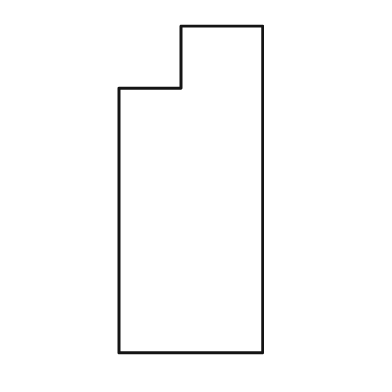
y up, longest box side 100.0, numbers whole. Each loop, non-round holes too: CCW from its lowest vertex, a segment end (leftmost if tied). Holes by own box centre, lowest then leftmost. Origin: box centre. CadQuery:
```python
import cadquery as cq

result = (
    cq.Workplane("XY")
    .moveTo(-22.0, -50.0)
    .lineTo(22.0, -50.0)
    .lineTo(22.0, 50.0)
    .lineTo(-3.0, 50.0)
    .lineTo(-3.0, 31.0)
    .lineTo(-22.0, 31.0)
    .close()
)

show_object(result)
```